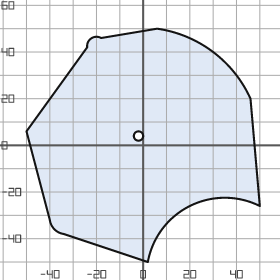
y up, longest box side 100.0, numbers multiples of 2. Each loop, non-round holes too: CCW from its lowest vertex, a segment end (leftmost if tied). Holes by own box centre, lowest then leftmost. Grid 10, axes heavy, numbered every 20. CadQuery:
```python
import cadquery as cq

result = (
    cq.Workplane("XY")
    .moveTo(2.0, -50.0)
    .threePointArc((20.0, -26.0), (50.0, -26.0))
    .lineTo(46.0, 20.0)
    .threePointArc((30.0, 40.0), (6.0, 50.0))
    .lineTo(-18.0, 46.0)
    .threePointArc((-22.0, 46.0), (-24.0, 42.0))
    .lineTo(-50.0, 6.0)
    .lineTo(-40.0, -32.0)
    .threePointArc((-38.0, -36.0), (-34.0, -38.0))
    .close()
    .moveTo(-2.0, 4.0)
    .circle(2.0)
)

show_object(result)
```